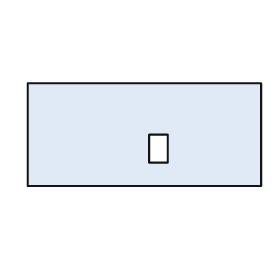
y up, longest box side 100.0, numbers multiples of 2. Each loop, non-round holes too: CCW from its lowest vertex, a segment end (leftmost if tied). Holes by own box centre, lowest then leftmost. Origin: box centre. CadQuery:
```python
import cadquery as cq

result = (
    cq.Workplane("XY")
    .moveTo(-50.0, -22.0)
    .lineTo(50.0, -22.0)
    .lineTo(50.0, 22.0)
    .lineTo(-50.0, 22.0)
    .close()
    .moveTo(2.0, -12.0)
    .lineTo(10.0, -12.0)
    .lineTo(10.0, 0.0)
    .lineTo(2.0, 0.0)
    .close()
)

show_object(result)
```